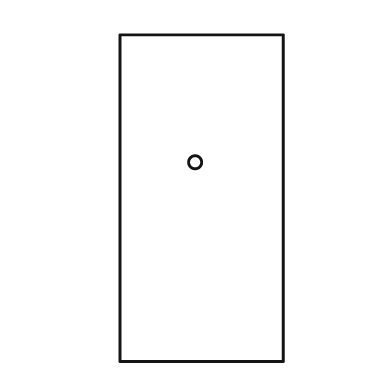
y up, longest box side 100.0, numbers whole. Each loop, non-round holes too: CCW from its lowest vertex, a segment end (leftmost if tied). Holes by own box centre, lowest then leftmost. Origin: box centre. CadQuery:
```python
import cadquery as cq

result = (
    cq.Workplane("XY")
    .moveTo(-25.0, -50.0)
    .lineTo(25.0, -50.0)
    .lineTo(25.0, 50.0)
    .lineTo(-25.0, 50.0)
    .close()
    .moveTo(-2.0, 11.0)
    .circle(2.0)
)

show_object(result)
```